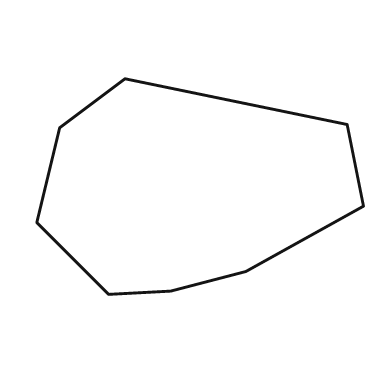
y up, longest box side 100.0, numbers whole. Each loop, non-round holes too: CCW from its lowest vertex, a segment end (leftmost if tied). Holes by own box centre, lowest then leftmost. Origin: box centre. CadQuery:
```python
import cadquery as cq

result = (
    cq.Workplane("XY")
    .moveTo(-28.0, -33.0)
    .lineTo(-9.0, -32.0)
    .lineTo(14.0, -26.0)
    .lineTo(50.0, -6.0)
    .lineTo(45.0, 19.0)
    .lineTo(-23.0, 33.0)
    .lineTo(-43.0, 18.0)
    .lineTo(-50.0, -11.0)
    .close()
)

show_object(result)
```